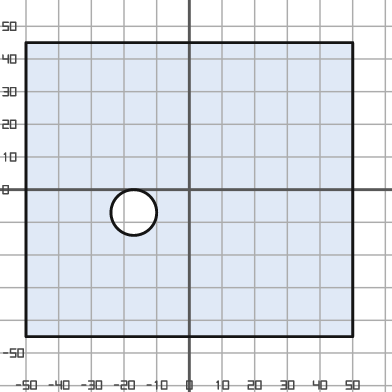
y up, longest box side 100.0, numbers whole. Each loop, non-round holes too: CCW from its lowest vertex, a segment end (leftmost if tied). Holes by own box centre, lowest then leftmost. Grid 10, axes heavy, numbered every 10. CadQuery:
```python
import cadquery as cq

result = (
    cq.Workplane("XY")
    .moveTo(-50.0, -45.0)
    .lineTo(50.0, -45.0)
    .lineTo(50.0, 45.0)
    .lineTo(-50.0, 45.0)
    .close()
    .moveTo(-17.0, -7.0)
    .circle(7.0)
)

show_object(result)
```